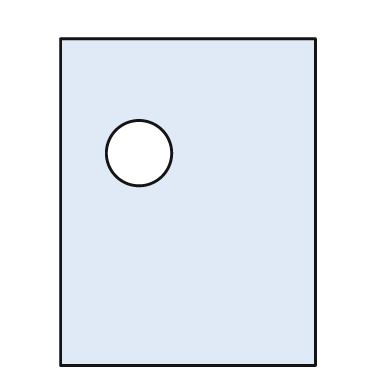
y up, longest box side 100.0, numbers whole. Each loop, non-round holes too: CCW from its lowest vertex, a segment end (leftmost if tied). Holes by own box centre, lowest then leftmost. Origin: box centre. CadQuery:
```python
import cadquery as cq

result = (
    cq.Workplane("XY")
    .moveTo(-39.0, -50.0)
    .lineTo(39.0, -50.0)
    .lineTo(39.0, 50.0)
    .lineTo(-39.0, 50.0)
    .close()
    .moveTo(-15.0, 15.0)
    .circle(10.0)
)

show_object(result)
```